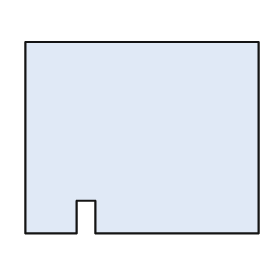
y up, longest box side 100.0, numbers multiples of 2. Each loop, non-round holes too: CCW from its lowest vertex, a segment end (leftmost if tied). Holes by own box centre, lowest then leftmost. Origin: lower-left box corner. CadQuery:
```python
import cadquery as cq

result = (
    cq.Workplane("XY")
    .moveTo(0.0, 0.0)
    .lineTo(22.0, 0.0)
    .lineTo(22.0, 14.0)
    .lineTo(30.0, 14.0)
    .lineTo(30.0, 0.0)
    .lineTo(100.0, 0.0)
    .lineTo(100.0, 82.0)
    .lineTo(0.0, 82.0)
    .close()
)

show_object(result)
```